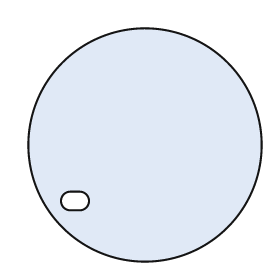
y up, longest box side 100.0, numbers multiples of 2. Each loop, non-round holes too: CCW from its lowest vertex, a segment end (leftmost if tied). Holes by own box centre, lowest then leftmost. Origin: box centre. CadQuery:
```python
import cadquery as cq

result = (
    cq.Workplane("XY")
    .moveTo(0.0, 0.0)
    .circle(50.0)
    .moveTo(-32.0, -28.0)
    .lineTo(-28.0, -28.0)
    .threePointArc((-24.0, -24.0), (-28.0, -20.0))
    .lineTo(-32.0, -20.0)
    .threePointArc((-36.0, -24.0), (-32.0, -28.0))
    .close()
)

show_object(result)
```